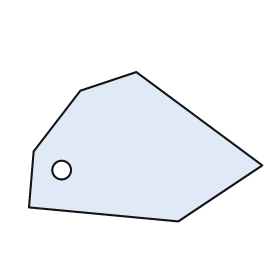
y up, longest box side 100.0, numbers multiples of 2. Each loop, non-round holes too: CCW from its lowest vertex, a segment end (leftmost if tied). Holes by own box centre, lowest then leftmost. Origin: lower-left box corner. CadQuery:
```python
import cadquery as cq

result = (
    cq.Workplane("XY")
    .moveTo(64.0, 0.0)
    .lineTo(100.0, 24.0)
    .lineTo(46.0, 64.0)
    .lineTo(22.0, 56.0)
    .lineTo(2.0, 30.0)
    .lineTo(0.0, 6.0)
    .close()
    .moveTo(14.0, 22.0)
    .circle(4.0)
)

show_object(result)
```